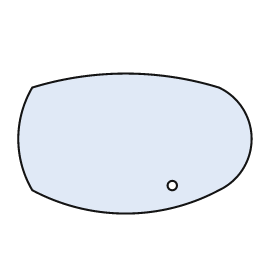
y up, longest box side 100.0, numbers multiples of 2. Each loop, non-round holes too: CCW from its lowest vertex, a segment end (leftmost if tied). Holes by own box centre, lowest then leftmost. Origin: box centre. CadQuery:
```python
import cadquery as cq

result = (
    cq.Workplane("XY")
    .moveTo(-44.0, -20.0)
    .threePointArc((-4.0, -30.0), (36.0, -20.0))
    .threePointArc((50.0, 2.0), (36.0, 24.0))
    .threePointArc((-4.0, 30.0), (-44.0, 24.0))
    .threePointArc((-50.0, 2.0), (-44.0, -20.0))
    .close()
    .moveTo(16.0, -18.0)
    .circle(2.0)
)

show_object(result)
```